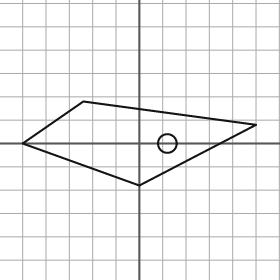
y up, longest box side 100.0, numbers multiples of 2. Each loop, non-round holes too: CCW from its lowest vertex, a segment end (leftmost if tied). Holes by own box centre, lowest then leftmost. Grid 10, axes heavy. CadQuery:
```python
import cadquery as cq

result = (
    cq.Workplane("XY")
    .moveTo(0.0, -18.0)
    .lineTo(50.0, 8.0)
    .lineTo(-24.0, 18.0)
    .lineTo(-50.0, 0.0)
    .close()
    .moveTo(12.0, 0.0)
    .circle(4.0)
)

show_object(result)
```